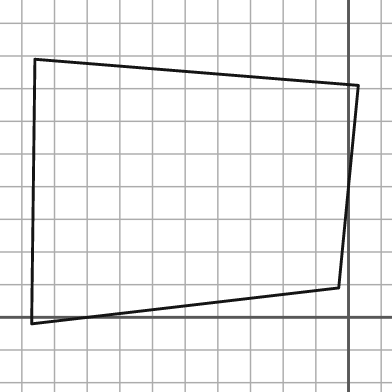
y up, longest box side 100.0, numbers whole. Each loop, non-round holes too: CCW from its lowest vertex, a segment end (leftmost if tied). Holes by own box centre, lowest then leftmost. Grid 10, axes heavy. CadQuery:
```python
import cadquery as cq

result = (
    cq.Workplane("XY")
    .moveTo(-97.0, -2.0)
    .lineTo(-3.0, 9.0)
    .lineTo(3.0, 71.0)
    .lineTo(-96.0, 79.0)
    .close()
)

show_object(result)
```